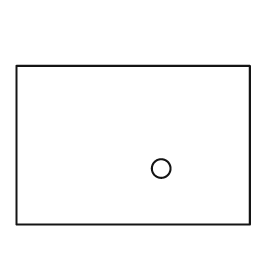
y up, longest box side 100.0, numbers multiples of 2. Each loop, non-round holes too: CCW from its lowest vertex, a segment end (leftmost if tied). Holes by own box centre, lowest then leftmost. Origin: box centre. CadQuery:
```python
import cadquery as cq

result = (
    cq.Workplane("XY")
    .moveTo(-50.0, -34.0)
    .lineTo(50.0, -34.0)
    .lineTo(50.0, 34.0)
    .lineTo(-50.0, 34.0)
    .close()
    .moveTo(12.0, -10.0)
    .circle(4.0)
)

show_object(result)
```